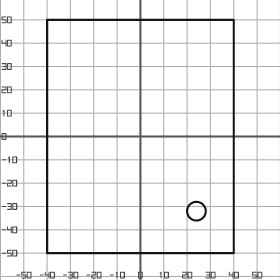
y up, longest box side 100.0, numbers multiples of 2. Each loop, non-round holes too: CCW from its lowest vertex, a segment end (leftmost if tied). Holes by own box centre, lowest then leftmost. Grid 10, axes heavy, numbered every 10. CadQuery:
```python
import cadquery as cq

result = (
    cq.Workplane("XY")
    .moveTo(-40.0, -50.0)
    .lineTo(40.0, -50.0)
    .lineTo(40.0, 50.0)
    .lineTo(-40.0, 50.0)
    .close()
    .moveTo(24.0, -32.0)
    .circle(4.0)
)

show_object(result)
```